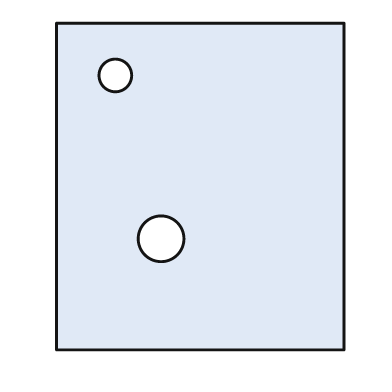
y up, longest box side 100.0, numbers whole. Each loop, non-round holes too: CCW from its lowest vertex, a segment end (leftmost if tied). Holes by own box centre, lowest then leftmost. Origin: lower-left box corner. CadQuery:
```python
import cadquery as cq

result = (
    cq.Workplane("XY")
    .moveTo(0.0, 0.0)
    .lineTo(88.0, 0.0)
    .lineTo(88.0, 100.0)
    .lineTo(0.0, 100.0)
    .close()
    .moveTo(32.0, 34.0)
    .circle(7.0)
    .moveTo(18.0, 84.0)
    .circle(5.0)
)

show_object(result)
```